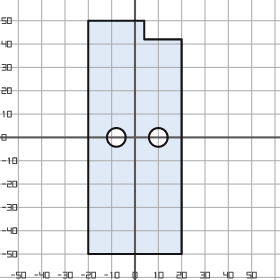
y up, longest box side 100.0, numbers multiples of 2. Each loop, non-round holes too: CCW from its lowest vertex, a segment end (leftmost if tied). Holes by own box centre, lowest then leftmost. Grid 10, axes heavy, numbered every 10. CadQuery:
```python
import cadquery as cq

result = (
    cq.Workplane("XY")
    .moveTo(-20.0, -50.0)
    .lineTo(20.0, -50.0)
    .lineTo(20.0, 42.0)
    .lineTo(4.0, 42.0)
    .lineTo(4.0, 50.0)
    .lineTo(-20.0, 50.0)
    .close()
    .moveTo(-8.0, 0.0)
    .circle(4.0)
    .moveTo(10.0, 0.0)
    .circle(4.0)
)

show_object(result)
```